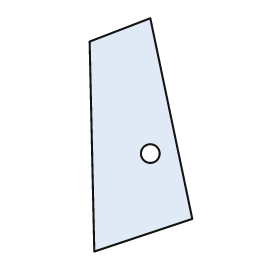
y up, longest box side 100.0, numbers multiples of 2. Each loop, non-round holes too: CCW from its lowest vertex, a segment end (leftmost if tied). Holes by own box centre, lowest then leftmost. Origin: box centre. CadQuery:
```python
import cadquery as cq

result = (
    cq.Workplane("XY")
    .moveTo(-20.0, -50.0)
    .lineTo(22.0, -36.0)
    .lineTo(4.0, 50.0)
    .lineTo(-22.0, 40.0)
    .close()
    .moveTo(4.0, -8.0)
    .circle(4.0)
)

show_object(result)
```